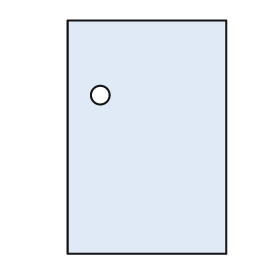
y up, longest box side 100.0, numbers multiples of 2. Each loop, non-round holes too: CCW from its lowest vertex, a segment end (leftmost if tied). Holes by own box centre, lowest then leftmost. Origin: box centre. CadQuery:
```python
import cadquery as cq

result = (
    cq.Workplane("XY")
    .moveTo(-34.0, -50.0)
    .lineTo(34.0, -50.0)
    .lineTo(34.0, 50.0)
    .lineTo(-34.0, 50.0)
    .close()
    .moveTo(-20.0, 18.0)
    .circle(4.0)
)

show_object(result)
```